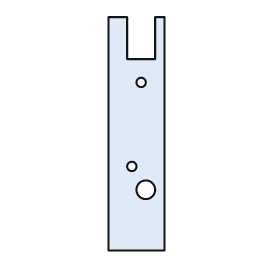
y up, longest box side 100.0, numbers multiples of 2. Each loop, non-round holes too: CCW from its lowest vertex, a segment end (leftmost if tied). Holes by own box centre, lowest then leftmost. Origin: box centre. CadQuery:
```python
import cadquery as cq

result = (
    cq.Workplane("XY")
    .moveTo(-12.0, -50.0)
    .lineTo(12.0, -50.0)
    .lineTo(12.0, 50.0)
    .lineTo(8.0, 50.0)
    .lineTo(8.0, 32.0)
    .lineTo(-4.0, 32.0)
    .lineTo(-4.0, 50.0)
    .lineTo(-12.0, 50.0)
    .close()
    .moveTo(4.0, -24.0)
    .circle(4.0)
    .moveTo(-2.0, -14.0)
    .circle(2.0)
    .moveTo(2.0, 22.0)
    .circle(2.0)
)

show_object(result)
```